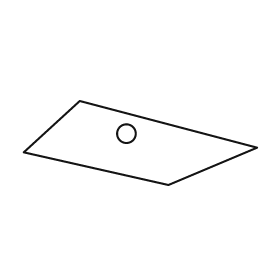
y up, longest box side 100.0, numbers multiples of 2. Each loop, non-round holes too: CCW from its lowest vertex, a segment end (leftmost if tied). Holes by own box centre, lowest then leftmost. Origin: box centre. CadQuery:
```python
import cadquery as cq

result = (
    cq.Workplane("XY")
    .moveTo(12.0, -18.0)
    .lineTo(50.0, -2.0)
    .lineTo(-26.0, 18.0)
    .lineTo(-50.0, -4.0)
    .close()
    .moveTo(-6.0, 4.0)
    .circle(4.0)
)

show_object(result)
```